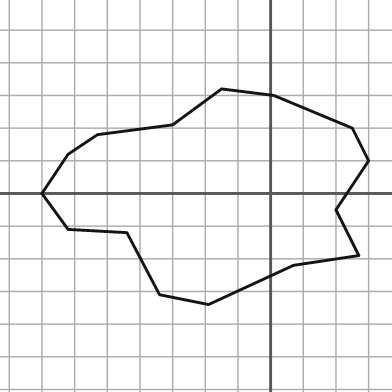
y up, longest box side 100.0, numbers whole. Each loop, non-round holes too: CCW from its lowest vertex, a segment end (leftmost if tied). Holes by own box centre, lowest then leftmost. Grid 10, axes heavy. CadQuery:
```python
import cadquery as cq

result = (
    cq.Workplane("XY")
    .moveTo(-19.0, -34.0)
    .lineTo(7.0, -22.0)
    .lineTo(27.0, -19.0)
    .lineTo(20.0, -5.0)
    .lineTo(30.0, 10.0)
    .lineTo(25.0, 20.0)
    .lineTo(1.0, 30.0)
    .lineTo(-15.0, 32.0)
    .lineTo(-30.0, 21.0)
    .lineTo(-53.0, 18.0)
    .lineTo(-62.0, 12.0)
    .lineTo(-70.0, 0.0)
    .lineTo(-62.0, -11.0)
    .lineTo(-44.0, -12.0)
    .lineTo(-34.0, -31.0)
    .close()
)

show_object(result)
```